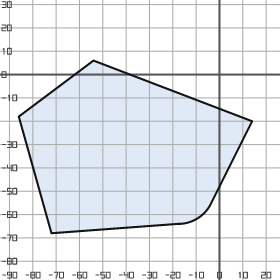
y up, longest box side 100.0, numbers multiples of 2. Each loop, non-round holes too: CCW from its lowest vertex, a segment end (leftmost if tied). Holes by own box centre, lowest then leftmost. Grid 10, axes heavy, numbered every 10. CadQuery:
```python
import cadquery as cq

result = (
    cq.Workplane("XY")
    .moveTo(-72.0, -68.0)
    .lineTo(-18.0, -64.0)
    .threePointArc((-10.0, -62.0), (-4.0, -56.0))
    .lineTo(14.0, -20.0)
    .lineTo(-54.0, 6.0)
    .lineTo(-86.0, -18.0)
    .close()
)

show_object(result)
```